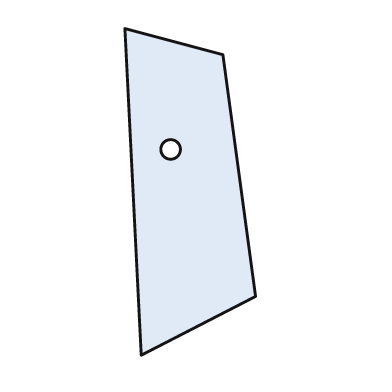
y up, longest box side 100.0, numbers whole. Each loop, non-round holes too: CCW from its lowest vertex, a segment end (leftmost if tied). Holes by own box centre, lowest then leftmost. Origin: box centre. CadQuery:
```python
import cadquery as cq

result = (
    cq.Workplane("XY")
    .moveTo(-15.0, -50.0)
    .lineTo(20.0, -32.0)
    .lineTo(10.0, 42.0)
    .lineTo(-20.0, 50.0)
    .close()
    .moveTo(-6.0, 13.0)
    .circle(3.0)
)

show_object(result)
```